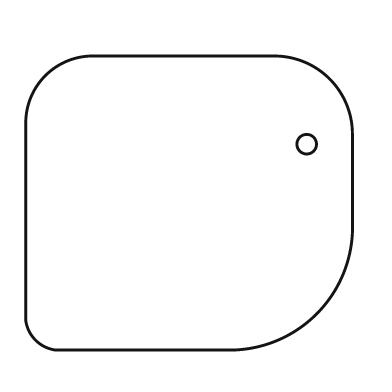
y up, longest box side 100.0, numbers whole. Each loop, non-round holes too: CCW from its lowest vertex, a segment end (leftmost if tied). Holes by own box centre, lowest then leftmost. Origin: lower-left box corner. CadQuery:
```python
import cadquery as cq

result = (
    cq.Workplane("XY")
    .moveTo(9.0, 0.0)
    .lineTo(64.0, 0.0)
    .threePointArc((89.0, 11.0), (100.0, 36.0))
    .lineTo(100.0, 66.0)
    .threePointArc((93.0, 83.0), (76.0, 90.0))
    .lineTo(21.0, 90.0)
    .threePointArc((6.0, 84.0), (0.0, 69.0))
    .lineTo(0.0, 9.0)
    .threePointArc((3.0, 3.0), (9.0, 0.0))
    .close()
    .moveTo(86.0, 63.0)
    .circle(3.0)
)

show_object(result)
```